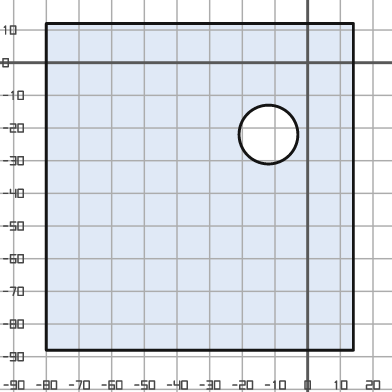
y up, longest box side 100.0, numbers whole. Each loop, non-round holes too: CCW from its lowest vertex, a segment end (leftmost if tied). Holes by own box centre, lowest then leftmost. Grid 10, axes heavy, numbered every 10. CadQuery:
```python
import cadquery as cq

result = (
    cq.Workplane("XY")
    .moveTo(-80.0, -88.0)
    .lineTo(14.0, -88.0)
    .lineTo(14.0, 12.0)
    .lineTo(-80.0, 12.0)
    .close()
    .moveTo(-12.0, -22.0)
    .circle(9.0)
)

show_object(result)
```